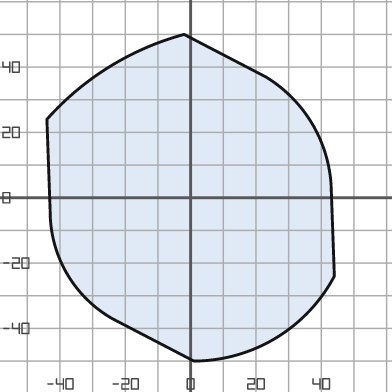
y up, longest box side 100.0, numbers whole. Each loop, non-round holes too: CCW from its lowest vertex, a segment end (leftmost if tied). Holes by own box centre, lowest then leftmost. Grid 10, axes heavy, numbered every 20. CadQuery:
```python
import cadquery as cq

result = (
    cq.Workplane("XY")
    .moveTo(1.0, -50.0)
    .threePointArc((26.0, -43.0), (44.0, -24.0))
    .lineTo(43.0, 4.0)
    .threePointArc((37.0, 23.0), (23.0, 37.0))
    .lineTo(-2.0, 50.0)
    .threePointArc((-25.0, 40.0), (-44.0, 24.0))
    .lineTo(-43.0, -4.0)
    .threePointArc((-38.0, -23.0), (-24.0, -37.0))
    .close()
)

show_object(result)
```